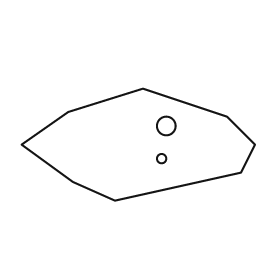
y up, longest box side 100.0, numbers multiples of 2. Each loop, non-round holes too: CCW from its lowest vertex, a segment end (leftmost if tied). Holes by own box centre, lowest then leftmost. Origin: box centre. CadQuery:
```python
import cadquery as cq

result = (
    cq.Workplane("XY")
    .moveTo(-10.0, -24.0)
    .lineTo(44.0, -12.0)
    .lineTo(50.0, 0.0)
    .lineTo(38.0, 12.0)
    .lineTo(2.0, 24.0)
    .lineTo(-30.0, 14.0)
    .lineTo(-50.0, 0.0)
    .lineTo(-28.0, -16.0)
    .close()
    .moveTo(10.0, -6.0)
    .circle(2.0)
    .moveTo(12.0, 8.0)
    .circle(4.0)
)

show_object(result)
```